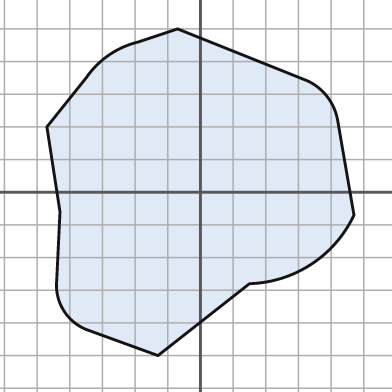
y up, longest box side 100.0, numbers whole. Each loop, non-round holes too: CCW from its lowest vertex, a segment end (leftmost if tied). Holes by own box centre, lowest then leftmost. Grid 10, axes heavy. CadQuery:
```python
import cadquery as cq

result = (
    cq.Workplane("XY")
    .moveTo(-13.0, -50.0)
    .lineTo(15.0, -28.0)
    .threePointArc((34.0, -22.0), (47.0, -7.0))
    .lineTo(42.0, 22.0)
    .threePointArc((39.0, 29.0), (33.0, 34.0))
    .lineTo(-7.0, 50.0)
    .lineTo(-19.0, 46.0)
    .threePointArc((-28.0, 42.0), (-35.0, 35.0))
    .lineTo(-47.0, 20.0)
    .lineTo(-43.0, -6.0)
    .lineTo(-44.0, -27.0)
    .threePointArc((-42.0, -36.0), (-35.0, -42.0))
    .close()
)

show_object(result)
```